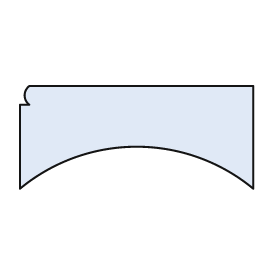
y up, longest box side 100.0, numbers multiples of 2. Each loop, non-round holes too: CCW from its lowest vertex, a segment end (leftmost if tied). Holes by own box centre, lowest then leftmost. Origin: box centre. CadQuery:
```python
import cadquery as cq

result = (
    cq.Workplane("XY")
    .moveTo(-50.0, -22.0)
    .threePointArc((0.0, -4.0), (50.0, -22.0))
    .lineTo(50.0, 22.0)
    .lineTo(-46.0, 22.0)
    .threePointArc((-48.0, 18.0), (-46.0, 14.0))
    .lineTo(-50.0, 14.0)
    .close()
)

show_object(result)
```